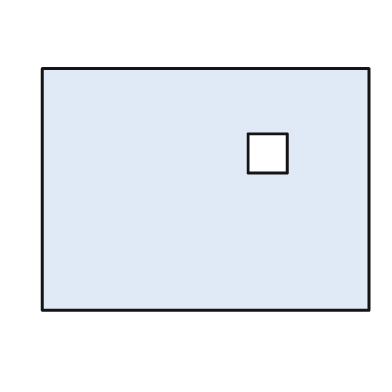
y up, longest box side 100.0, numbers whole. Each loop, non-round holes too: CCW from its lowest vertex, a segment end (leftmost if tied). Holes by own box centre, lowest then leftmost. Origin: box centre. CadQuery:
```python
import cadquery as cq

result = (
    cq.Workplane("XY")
    .moveTo(-50.0, -37.0)
    .lineTo(50.0, -37.0)
    .lineTo(50.0, 37.0)
    .lineTo(-50.0, 37.0)
    .close()
    .moveTo(13.0, 5.0)
    .lineTo(25.0, 5.0)
    .lineTo(25.0, 17.0)
    .lineTo(13.0, 17.0)
    .close()
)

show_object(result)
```